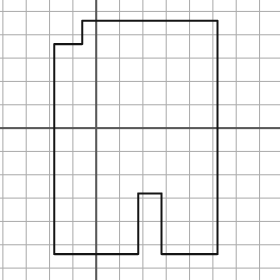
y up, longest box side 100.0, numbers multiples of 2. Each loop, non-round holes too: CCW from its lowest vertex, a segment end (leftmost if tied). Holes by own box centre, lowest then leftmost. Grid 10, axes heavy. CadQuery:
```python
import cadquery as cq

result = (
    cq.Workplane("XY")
    .moveTo(-18.0, -54.0)
    .lineTo(18.0, -54.0)
    .lineTo(18.0, -28.0)
    .lineTo(28.0, -28.0)
    .lineTo(28.0, -54.0)
    .lineTo(52.0, -54.0)
    .lineTo(52.0, 46.0)
    .lineTo(-6.0, 46.0)
    .lineTo(-6.0, 36.0)
    .lineTo(-18.0, 36.0)
    .close()
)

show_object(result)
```